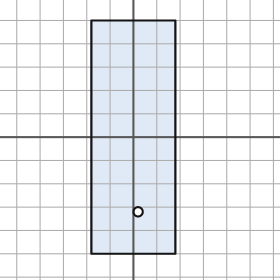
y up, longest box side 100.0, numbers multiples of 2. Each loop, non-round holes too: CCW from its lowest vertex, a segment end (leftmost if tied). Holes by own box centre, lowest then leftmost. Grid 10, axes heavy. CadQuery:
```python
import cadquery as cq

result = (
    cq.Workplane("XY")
    .moveTo(-18.0, -50.0)
    .lineTo(18.0, -50.0)
    .lineTo(18.0, 50.0)
    .lineTo(-18.0, 50.0)
    .close()
    .moveTo(2.0, -32.0)
    .circle(2.0)
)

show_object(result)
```